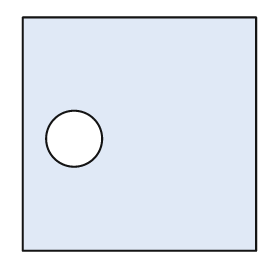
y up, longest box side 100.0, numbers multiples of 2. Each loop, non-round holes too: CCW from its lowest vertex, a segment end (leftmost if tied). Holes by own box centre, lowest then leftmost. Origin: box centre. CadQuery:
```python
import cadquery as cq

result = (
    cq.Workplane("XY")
    .moveTo(-50.0, -50.0)
    .lineTo(50.0, -50.0)
    .lineTo(50.0, 50.0)
    .lineTo(-50.0, 50.0)
    .close()
    .moveTo(-28.0, -2.0)
    .circle(12.0)
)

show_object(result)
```